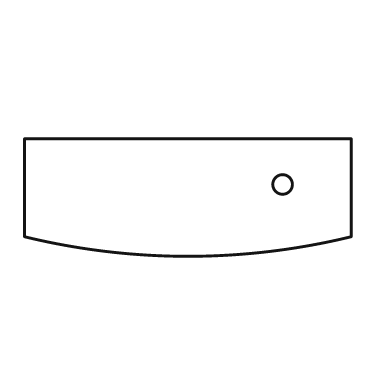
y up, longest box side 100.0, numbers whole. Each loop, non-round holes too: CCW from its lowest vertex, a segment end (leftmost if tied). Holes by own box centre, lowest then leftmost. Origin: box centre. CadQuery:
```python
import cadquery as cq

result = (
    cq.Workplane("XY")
    .moveTo(-50.0, -12.0)
    .threePointArc((0.0, -18.0), (50.0, -12.0))
    .lineTo(50.0, 18.0)
    .lineTo(-50.0, 18.0)
    .close()
    .moveTo(29.0, 4.0)
    .circle(3.0)
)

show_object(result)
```